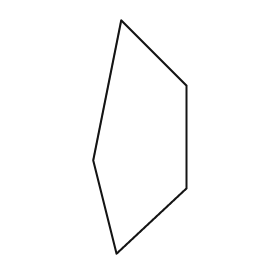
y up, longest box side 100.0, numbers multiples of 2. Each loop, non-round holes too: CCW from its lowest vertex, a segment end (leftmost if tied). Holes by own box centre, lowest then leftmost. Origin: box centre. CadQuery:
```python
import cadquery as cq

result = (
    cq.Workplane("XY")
    .moveTo(-10.0, -50.0)
    .lineTo(20.0, -22.0)
    .lineTo(20.0, 22.0)
    .lineTo(-8.0, 50.0)
    .lineTo(-20.0, -10.0)
    .close()
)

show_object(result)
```